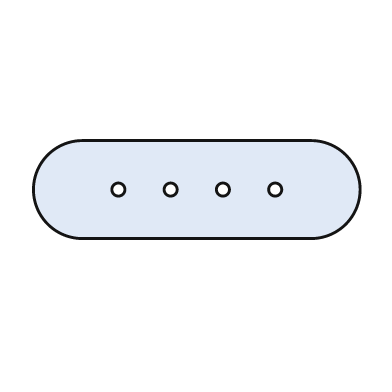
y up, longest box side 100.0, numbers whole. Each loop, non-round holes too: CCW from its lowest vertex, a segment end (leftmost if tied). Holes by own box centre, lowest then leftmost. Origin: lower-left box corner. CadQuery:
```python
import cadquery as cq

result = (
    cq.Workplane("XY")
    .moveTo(15.0, 0.0)
    .lineTo(85.0, 0.0)
    .threePointArc((100.0, 15.0), (85.0, 30.0))
    .lineTo(15.0, 30.0)
    .threePointArc((0.0, 15.0), (15.0, 0.0))
    .close()
    .moveTo(26.0, 15.0)
    .circle(2.0)
    .moveTo(42.0, 15.0)
    .circle(2.0)
    .moveTo(58.0, 15.0)
    .circle(2.0)
    .moveTo(74.0, 15.0)
    .circle(2.0)
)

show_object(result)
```